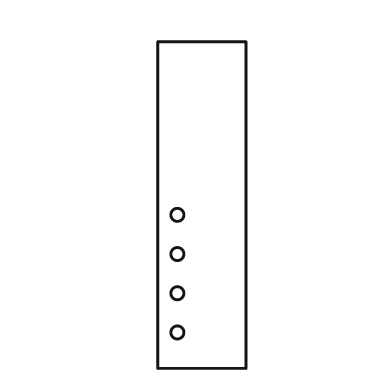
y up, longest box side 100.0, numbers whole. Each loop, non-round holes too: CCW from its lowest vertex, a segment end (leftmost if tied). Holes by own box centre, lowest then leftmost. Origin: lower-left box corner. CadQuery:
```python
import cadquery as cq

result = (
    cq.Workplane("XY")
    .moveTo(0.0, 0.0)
    .lineTo(27.0, 0.0)
    .lineTo(27.0, 100.0)
    .lineTo(0.0, 100.0)
    .close()
    .moveTo(6.0, 11.0)
    .circle(2.0)
    .moveTo(6.0, 23.0)
    .circle(2.0)
    .moveTo(6.0, 35.0)
    .circle(2.0)
    .moveTo(6.0, 47.0)
    .circle(2.0)
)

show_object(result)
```